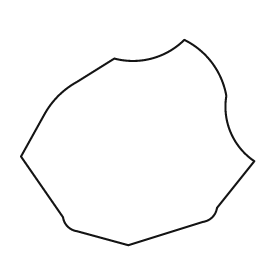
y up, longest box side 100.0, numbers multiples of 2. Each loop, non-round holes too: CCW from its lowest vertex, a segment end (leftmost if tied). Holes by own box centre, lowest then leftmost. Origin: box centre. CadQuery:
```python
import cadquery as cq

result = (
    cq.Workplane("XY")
    .moveTo(-4.0, -44.0)
    .lineTo(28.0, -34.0)
    .threePointArc((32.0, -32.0), (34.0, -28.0))
    .lineTo(50.0, -8.0)
    .threePointArc((40.0, 4.0), (38.0, 20.0))
    .threePointArc((32.0, 34.0), (20.0, 44.0))
    .threePointArc((6.0, 36.0), (-10.0, 36.0))
    .lineTo(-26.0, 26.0)
    .threePointArc((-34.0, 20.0), (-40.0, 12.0))
    .lineTo(-50.0, -6.0)
    .lineTo(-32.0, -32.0)
    .threePointArc((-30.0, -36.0), (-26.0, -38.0))
    .close()
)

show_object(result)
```